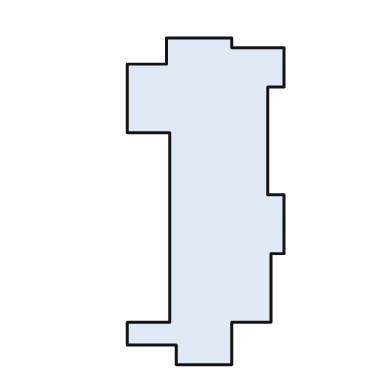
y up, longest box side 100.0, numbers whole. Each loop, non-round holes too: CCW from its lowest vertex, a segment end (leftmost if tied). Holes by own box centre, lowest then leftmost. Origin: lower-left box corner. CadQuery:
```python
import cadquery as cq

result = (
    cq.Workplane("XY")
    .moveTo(15.0, 0.0)
    .lineTo(32.0, 0.0)
    .lineTo(32.0, 13.0)
    .lineTo(44.0, 13.0)
    .lineTo(44.0, 34.0)
    .lineTo(48.0, 34.0)
    .lineTo(48.0, 52.0)
    .lineTo(43.0, 52.0)
    .lineTo(43.0, 85.0)
    .lineTo(48.0, 85.0)
    .lineTo(48.0, 97.0)
    .lineTo(32.0, 97.0)
    .lineTo(32.0, 100.0)
    .lineTo(12.0, 100.0)
    .lineTo(12.0, 92.0)
    .lineTo(0.0, 92.0)
    .lineTo(0.0, 71.0)
    .lineTo(13.0, 71.0)
    .lineTo(13.0, 13.0)
    .lineTo(0.0, 13.0)
    .lineTo(0.0, 6.0)
    .lineTo(15.0, 6.0)
    .close()
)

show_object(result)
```